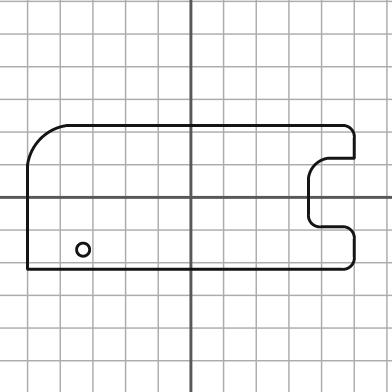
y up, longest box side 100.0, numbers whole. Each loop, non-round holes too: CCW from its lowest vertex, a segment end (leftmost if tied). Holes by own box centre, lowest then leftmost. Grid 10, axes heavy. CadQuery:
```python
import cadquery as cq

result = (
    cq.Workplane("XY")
    .moveTo(-50.0, -22.0)
    .lineTo(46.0, -22.0)
    .threePointArc((49.0, -21.0), (50.0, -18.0))
    .lineTo(50.0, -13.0)
    .threePointArc((49.0, -10.0), (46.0, -9.0))
    .lineTo(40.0, -9.0)
    .threePointArc((37.0, -8.0), (36.0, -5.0))
    .lineTo(36.0, 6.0)
    .threePointArc((38.0, 10.0), (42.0, 12.0))
    .lineTo(50.0, 12.0)
    .lineTo(50.0, 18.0)
    .threePointArc((49.0, 21.0), (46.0, 22.0))
    .lineTo(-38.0, 22.0)
    .threePointArc((-46.0, 18.0), (-50.0, 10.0))
    .close()
    .moveTo(-33.0, -16.0)
    .circle(2.0)
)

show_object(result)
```